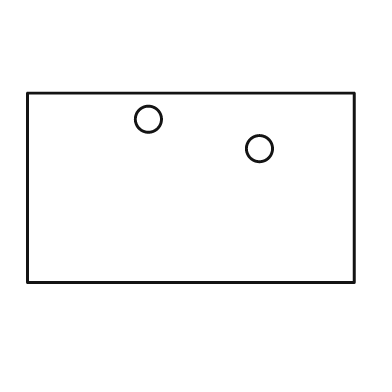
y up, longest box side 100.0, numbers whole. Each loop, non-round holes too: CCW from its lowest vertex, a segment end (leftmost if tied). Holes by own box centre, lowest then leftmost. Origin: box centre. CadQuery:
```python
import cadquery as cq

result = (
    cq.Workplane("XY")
    .moveTo(-50.0, -29.0)
    .lineTo(50.0, -29.0)
    .lineTo(50.0, 29.0)
    .lineTo(-50.0, 29.0)
    .close()
    .moveTo(21.0, 12.0)
    .circle(4.0)
    .moveTo(-13.0, 21.0)
    .circle(4.0)
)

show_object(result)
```